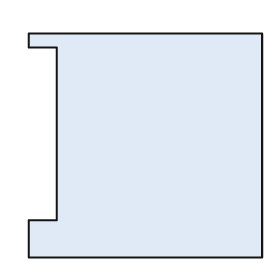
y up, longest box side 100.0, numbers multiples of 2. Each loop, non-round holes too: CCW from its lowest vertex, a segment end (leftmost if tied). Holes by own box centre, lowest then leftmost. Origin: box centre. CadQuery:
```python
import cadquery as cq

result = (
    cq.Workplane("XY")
    .moveTo(-50.0, -48.0)
    .lineTo(50.0, -48.0)
    .lineTo(50.0, 48.0)
    .lineTo(-50.0, 48.0)
    .lineTo(-50.0, 42.0)
    .lineTo(-38.0, 42.0)
    .lineTo(-38.0, -32.0)
    .lineTo(-50.0, -32.0)
    .close()
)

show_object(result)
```